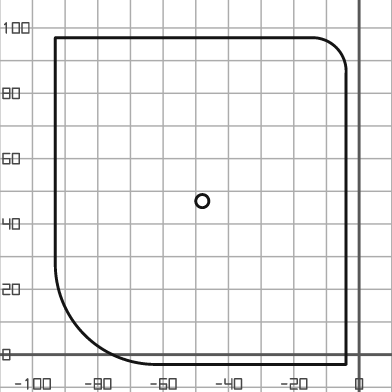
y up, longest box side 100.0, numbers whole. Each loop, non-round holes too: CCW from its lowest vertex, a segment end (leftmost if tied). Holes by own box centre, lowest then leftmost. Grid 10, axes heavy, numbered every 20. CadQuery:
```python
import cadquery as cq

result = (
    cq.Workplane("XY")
    .moveTo(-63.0, -3.0)
    .lineTo(-4.0, -3.0)
    .lineTo(-4.0, 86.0)
    .threePointArc((-7.0, 94.0), (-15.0, 97.0))
    .lineTo(-93.0, 97.0)
    .lineTo(-93.0, 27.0)
    .threePointArc((-84.0, 6.0), (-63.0, -3.0))
    .close()
    .moveTo(-48.0, 47.0)
    .circle(2.0)
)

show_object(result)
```